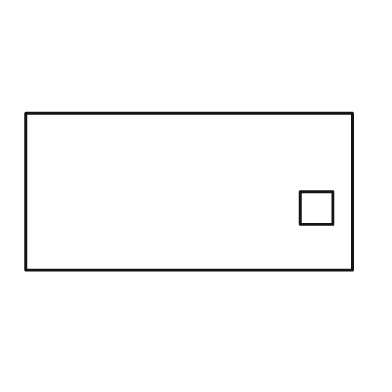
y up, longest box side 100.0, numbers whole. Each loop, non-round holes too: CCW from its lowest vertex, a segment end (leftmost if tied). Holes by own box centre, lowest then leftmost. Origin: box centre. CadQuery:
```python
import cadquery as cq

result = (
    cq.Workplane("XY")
    .moveTo(-50.0, -24.0)
    .lineTo(50.0, -24.0)
    .lineTo(50.0, 24.0)
    .lineTo(-50.0, 24.0)
    .close()
    .moveTo(34.0, -10.0)
    .lineTo(44.0, -10.0)
    .lineTo(44.0, 0.0)
    .lineTo(34.0, 0.0)
    .close()
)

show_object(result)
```